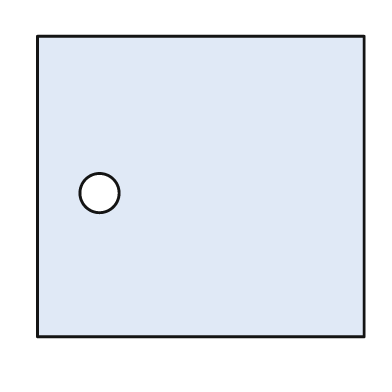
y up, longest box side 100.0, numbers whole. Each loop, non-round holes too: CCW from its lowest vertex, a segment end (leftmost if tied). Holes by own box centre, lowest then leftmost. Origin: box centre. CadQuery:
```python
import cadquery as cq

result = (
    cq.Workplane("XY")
    .moveTo(-50.0, -46.0)
    .lineTo(50.0, -46.0)
    .lineTo(50.0, 46.0)
    .lineTo(-50.0, 46.0)
    .close()
    .moveTo(-31.0, -2.0)
    .circle(6.0)
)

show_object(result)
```